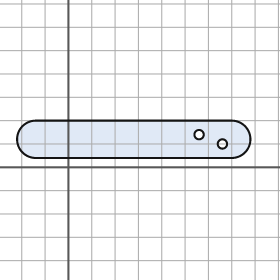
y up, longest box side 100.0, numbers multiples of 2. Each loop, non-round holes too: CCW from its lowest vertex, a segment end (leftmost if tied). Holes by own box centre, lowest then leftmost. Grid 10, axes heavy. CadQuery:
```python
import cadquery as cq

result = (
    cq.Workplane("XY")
    .moveTo(-14.0, 4.0)
    .lineTo(70.0, 4.0)
    .threePointArc((78.0, 12.0), (70.0, 20.0))
    .lineTo(-14.0, 20.0)
    .threePointArc((-22.0, 12.0), (-14.0, 4.0))
    .close()
    .moveTo(66.0, 10.0)
    .circle(2.0)
    .moveTo(56.0, 14.0)
    .circle(2.0)
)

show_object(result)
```